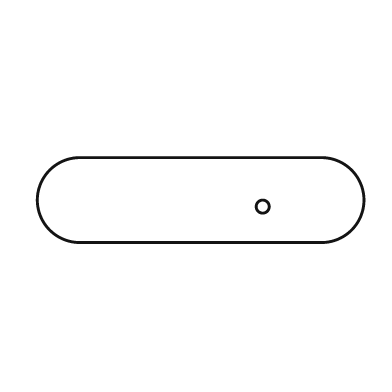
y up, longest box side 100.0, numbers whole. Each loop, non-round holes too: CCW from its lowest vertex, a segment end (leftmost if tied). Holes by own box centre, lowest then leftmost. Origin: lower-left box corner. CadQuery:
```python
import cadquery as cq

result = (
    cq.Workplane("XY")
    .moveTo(13.0, 0.0)
    .lineTo(87.0, 0.0)
    .threePointArc((100.0, 13.0), (87.0, 26.0))
    .lineTo(13.0, 26.0)
    .threePointArc((0.0, 13.0), (13.0, 0.0))
    .close()
    .moveTo(69.0, 11.0)
    .circle(2.0)
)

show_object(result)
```